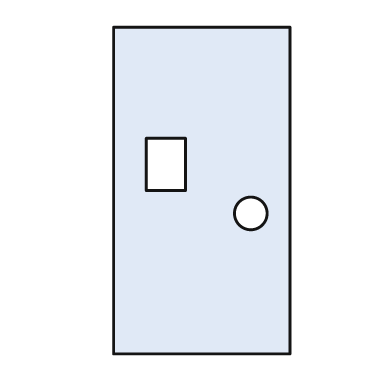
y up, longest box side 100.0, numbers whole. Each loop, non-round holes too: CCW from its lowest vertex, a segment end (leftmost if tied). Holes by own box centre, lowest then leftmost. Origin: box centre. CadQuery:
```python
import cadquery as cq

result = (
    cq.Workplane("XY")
    .moveTo(-27.0, -50.0)
    .lineTo(27.0, -50.0)
    .lineTo(27.0, 50.0)
    .lineTo(-27.0, 50.0)
    .close()
    .moveTo(15.0, -7.0)
    .circle(5.0)
    .moveTo(-17.0, 0.0)
    .lineTo(-5.0, 0.0)
    .lineTo(-5.0, 16.0)
    .lineTo(-17.0, 16.0)
    .close()
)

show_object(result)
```